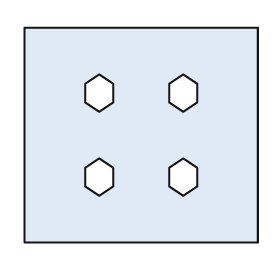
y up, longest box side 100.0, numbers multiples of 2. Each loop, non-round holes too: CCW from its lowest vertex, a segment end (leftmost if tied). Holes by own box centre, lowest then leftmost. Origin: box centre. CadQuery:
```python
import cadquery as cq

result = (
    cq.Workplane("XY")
    .moveTo(-50.0, -46.0)
    .lineTo(50.0, -46.0)
    .lineTo(50.0, 46.0)
    .lineTo(-50.0, 46.0)
    .close()
    .moveTo(-18.0, -26.0)
    .lineTo(-12.0, -22.0)
    .lineTo(-12.0, -14.0)
    .lineTo(-18.0, -10.0)
    .lineTo(-24.0, -14.0)
    .lineTo(-24.0, -22.0)
    .close()
    .moveTo(18.0, -26.0)
    .lineTo(24.0, -22.0)
    .lineTo(24.0, -14.0)
    .lineTo(18.0, -10.0)
    .lineTo(12.0, -14.0)
    .lineTo(12.0, -22.0)
    .close()
    .moveTo(-18.0, 10.0)
    .lineTo(-12.0, 14.0)
    .lineTo(-12.0, 22.0)
    .lineTo(-18.0, 26.0)
    .lineTo(-24.0, 22.0)
    .lineTo(-24.0, 14.0)
    .close()
    .moveTo(18.0, 10.0)
    .lineTo(24.0, 14.0)
    .lineTo(24.0, 22.0)
    .lineTo(18.0, 26.0)
    .lineTo(12.0, 22.0)
    .lineTo(12.0, 14.0)
    .close()
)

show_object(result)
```